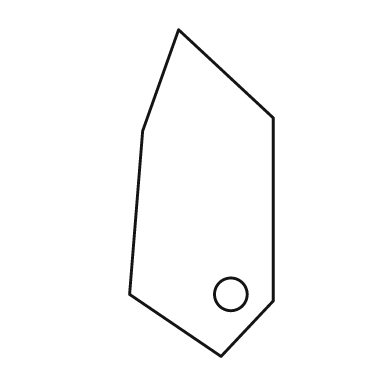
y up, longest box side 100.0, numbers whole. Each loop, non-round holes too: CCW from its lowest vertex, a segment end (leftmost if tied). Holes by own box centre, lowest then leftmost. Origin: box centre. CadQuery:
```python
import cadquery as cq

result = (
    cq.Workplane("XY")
    .moveTo(6.0, -50.0)
    .lineTo(22.0, -33.0)
    .lineTo(22.0, 23.0)
    .lineTo(-7.0, 50.0)
    .lineTo(-18.0, 19.0)
    .lineTo(-22.0, -31.0)
    .close()
    .moveTo(9.0, -31.0)
    .circle(5.0)
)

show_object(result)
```